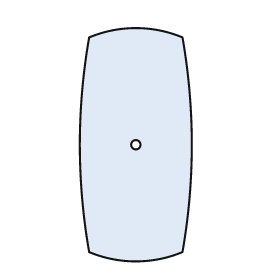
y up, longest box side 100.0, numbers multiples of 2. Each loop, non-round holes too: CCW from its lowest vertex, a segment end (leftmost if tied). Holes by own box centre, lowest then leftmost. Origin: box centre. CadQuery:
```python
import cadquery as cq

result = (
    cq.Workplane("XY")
    .moveTo(-20.0, -46.0)
    .threePointArc((0.0, -50.0), (20.0, -46.0))
    .threePointArc((24.0, 0.0), (20.0, 46.0))
    .threePointArc((0.0, 50.0), (-20.0, 46.0))
    .threePointArc((-24.0, 0.0), (-20.0, -46.0))
    .close()
    .moveTo(0.0, 0.0)
    .circle(2.0)
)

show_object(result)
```